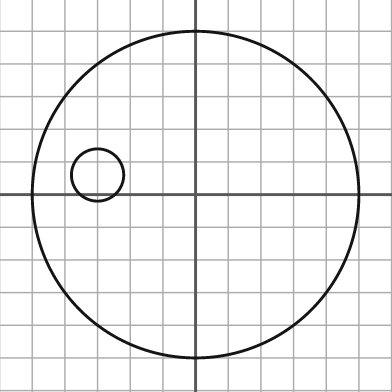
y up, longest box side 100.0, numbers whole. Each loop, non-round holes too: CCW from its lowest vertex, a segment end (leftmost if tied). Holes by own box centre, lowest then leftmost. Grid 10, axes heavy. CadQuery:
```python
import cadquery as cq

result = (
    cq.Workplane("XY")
    .moveTo(0.0, 0.0)
    .circle(50.0)
    .moveTo(-30.0, 6.0)
    .circle(8.0)
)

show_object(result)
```